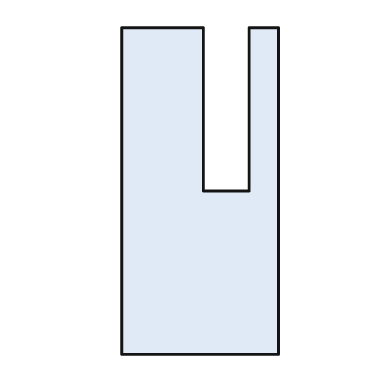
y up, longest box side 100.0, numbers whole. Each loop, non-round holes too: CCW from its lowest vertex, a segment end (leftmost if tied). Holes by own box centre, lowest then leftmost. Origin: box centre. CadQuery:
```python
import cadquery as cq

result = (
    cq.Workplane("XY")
    .moveTo(-24.0, -50.0)
    .lineTo(24.0, -50.0)
    .lineTo(24.0, 50.0)
    .lineTo(15.0, 50.0)
    .lineTo(15.0, 0.0)
    .lineTo(1.0, 0.0)
    .lineTo(1.0, 50.0)
    .lineTo(-24.0, 50.0)
    .close()
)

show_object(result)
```